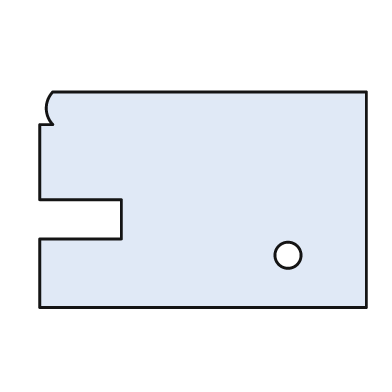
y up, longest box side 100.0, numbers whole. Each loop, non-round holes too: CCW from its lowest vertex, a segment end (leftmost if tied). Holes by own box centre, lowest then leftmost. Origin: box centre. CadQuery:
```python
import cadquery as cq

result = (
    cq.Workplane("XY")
    .moveTo(-50.0, -33.0)
    .lineTo(50.0, -33.0)
    .lineTo(50.0, 33.0)
    .lineTo(-46.0, 33.0)
    .threePointArc((-48.0, 28.0), (-46.0, 23.0))
    .lineTo(-50.0, 23.0)
    .lineTo(-50.0, 0.0)
    .lineTo(-25.0, 0.0)
    .lineTo(-25.0, -12.0)
    .lineTo(-50.0, -12.0)
    .close()
    .moveTo(26.0, -17.0)
    .circle(4.0)
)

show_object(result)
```